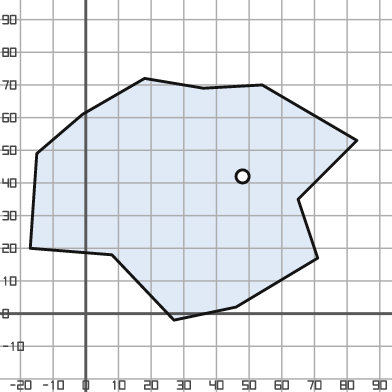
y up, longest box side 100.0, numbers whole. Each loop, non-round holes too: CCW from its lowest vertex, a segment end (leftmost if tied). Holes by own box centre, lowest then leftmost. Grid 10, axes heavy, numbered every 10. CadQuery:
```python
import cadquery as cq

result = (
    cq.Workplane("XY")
    .moveTo(27.0, -2.0)
    .lineTo(46.0, 2.0)
    .lineTo(71.0, 17.0)
    .lineTo(65.0, 35.0)
    .lineTo(83.0, 53.0)
    .lineTo(54.0, 70.0)
    .lineTo(36.0, 69.0)
    .lineTo(18.0, 72.0)
    .lineTo(-1.0, 61.0)
    .lineTo(-15.0, 49.0)
    .lineTo(-17.0, 20.0)
    .lineTo(8.0, 18.0)
    .close()
    .moveTo(48.0, 42.0)
    .circle(2.0)
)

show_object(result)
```